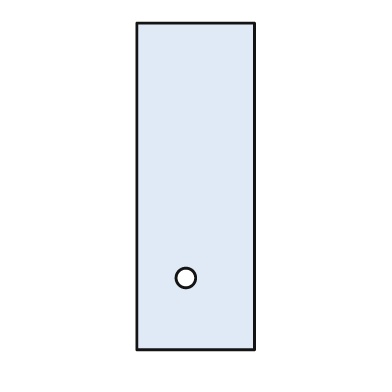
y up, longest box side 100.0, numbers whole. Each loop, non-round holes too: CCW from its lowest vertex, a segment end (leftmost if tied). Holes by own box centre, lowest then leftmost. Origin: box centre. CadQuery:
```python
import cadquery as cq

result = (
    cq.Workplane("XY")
    .moveTo(-18.0, -50.0)
    .lineTo(18.0, -50.0)
    .lineTo(18.0, 50.0)
    .lineTo(-18.0, 50.0)
    .close()
    .moveTo(-3.0, -28.0)
    .circle(3.0)
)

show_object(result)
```